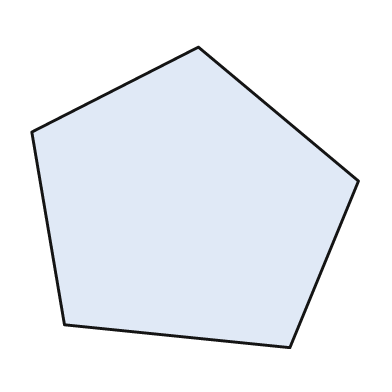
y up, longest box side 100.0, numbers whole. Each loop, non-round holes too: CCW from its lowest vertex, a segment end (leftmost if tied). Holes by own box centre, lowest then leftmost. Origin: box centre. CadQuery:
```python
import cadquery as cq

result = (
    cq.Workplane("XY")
    .moveTo(29.0, -46.0)
    .lineTo(50.0, 5.0)
    .lineTo(1.0, 46.0)
    .lineTo(-50.0, 20.0)
    .lineTo(-40.0, -39.0)
    .close()
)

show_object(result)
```